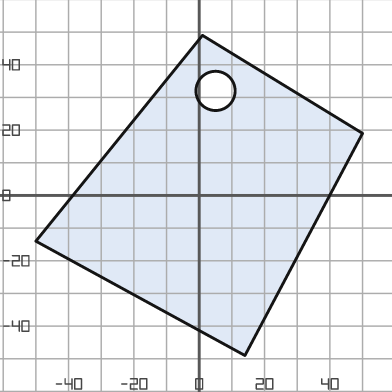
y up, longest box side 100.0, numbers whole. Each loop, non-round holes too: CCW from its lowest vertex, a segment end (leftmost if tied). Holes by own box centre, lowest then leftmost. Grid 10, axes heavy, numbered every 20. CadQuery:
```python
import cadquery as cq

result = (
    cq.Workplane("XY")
    .moveTo(14.0, -49.0)
    .lineTo(50.0, 19.0)
    .lineTo(1.0, 49.0)
    .lineTo(-50.0, -14.0)
    .close()
    .moveTo(5.0, 32.0)
    .circle(6.0)
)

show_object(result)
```